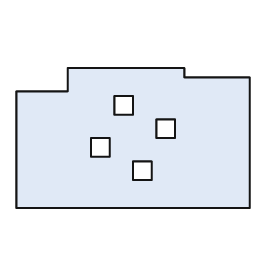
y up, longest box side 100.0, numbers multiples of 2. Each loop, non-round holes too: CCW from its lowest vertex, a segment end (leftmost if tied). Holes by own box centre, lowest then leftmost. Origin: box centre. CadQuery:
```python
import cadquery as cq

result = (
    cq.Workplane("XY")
    .moveTo(-50.0, -30.0)
    .lineTo(50.0, -30.0)
    .lineTo(50.0, 26.0)
    .lineTo(22.0, 26.0)
    .lineTo(22.0, 30.0)
    .lineTo(-28.0, 30.0)
    .lineTo(-28.0, 20.0)
    .lineTo(-50.0, 20.0)
    .close()
    .moveTo(0.0, -18.0)
    .lineTo(8.0, -18.0)
    .lineTo(8.0, -10.0)
    .lineTo(0.0, -10.0)
    .close()
    .moveTo(-18.0, -8.0)
    .lineTo(-10.0, -8.0)
    .lineTo(-10.0, 0.0)
    .lineTo(-18.0, 0.0)
    .close()
    .moveTo(10.0, 0.0)
    .lineTo(18.0, 0.0)
    .lineTo(18.0, 8.0)
    .lineTo(10.0, 8.0)
    .close()
    .moveTo(-8.0, 10.0)
    .lineTo(0.0, 10.0)
    .lineTo(0.0, 18.0)
    .lineTo(-8.0, 18.0)
    .close()
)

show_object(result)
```